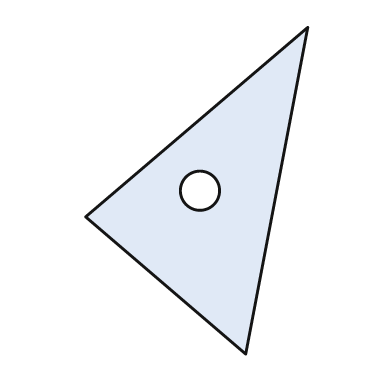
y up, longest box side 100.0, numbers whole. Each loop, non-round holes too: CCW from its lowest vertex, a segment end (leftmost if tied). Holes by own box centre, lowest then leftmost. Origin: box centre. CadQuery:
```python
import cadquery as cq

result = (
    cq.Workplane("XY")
    .moveTo(15.0, -50.0)
    .lineTo(34.0, 50.0)
    .lineTo(-34.0, -8.0)
    .close()
    .moveTo(1.0, 0.0)
    .circle(6.0)
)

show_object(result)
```